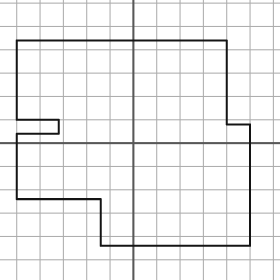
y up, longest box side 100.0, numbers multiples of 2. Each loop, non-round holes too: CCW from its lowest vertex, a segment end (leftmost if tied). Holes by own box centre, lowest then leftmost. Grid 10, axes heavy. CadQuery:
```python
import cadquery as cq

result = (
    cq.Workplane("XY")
    .moveTo(-14.0, -44.0)
    .lineTo(50.0, -44.0)
    .lineTo(50.0, 8.0)
    .lineTo(40.0, 8.0)
    .lineTo(40.0, 44.0)
    .lineTo(-50.0, 44.0)
    .lineTo(-50.0, 10.0)
    .lineTo(-32.0, 10.0)
    .lineTo(-32.0, 4.0)
    .lineTo(-50.0, 4.0)
    .lineTo(-50.0, -24.0)
    .lineTo(-14.0, -24.0)
    .close()
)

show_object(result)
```